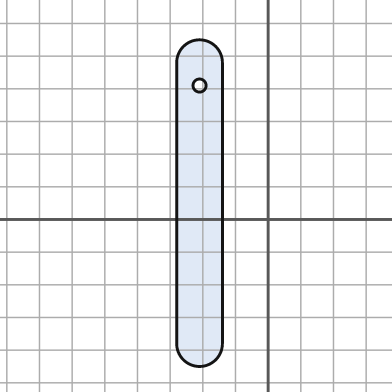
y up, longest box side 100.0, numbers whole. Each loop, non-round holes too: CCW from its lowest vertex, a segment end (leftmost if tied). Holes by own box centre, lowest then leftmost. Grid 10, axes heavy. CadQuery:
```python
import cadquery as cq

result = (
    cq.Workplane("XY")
    .moveTo(-28.0, -38.0)
    .threePointArc((-21.0, -45.0), (-14.0, -38.0))
    .lineTo(-14.0, 48.0)
    .threePointArc((-21.0, 55.0), (-28.0, 48.0))
    .close()
    .moveTo(-21.0, 41.0)
    .circle(2.0)
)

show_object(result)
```